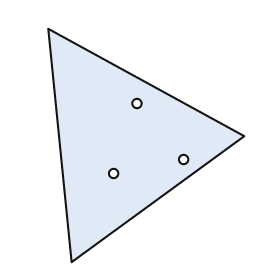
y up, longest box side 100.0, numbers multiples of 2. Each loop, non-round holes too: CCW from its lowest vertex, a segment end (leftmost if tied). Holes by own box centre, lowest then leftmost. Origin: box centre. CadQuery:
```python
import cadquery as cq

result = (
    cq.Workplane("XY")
    .moveTo(-32.0, -50.0)
    .lineTo(42.0, 4.0)
    .lineTo(-42.0, 50.0)
    .close()
    .moveTo(-14.0, -12.0)
    .circle(2.0)
    .moveTo(16.0, -6.0)
    .circle(2.0)
    .moveTo(-4.0, 18.0)
    .circle(2.0)
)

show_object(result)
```